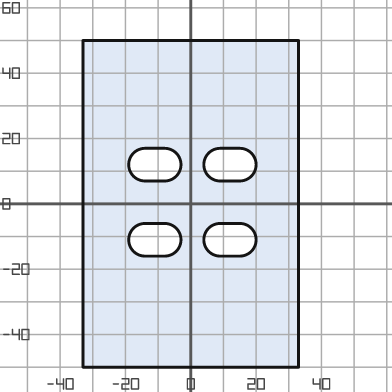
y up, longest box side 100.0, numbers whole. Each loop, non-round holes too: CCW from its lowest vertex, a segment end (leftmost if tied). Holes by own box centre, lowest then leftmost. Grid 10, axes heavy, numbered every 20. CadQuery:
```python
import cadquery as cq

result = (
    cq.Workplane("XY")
    .moveTo(-33.0, -50.0)
    .lineTo(33.0, -50.0)
    .lineTo(33.0, 50.0)
    .lineTo(-33.0, 50.0)
    .close()
    .moveTo(-14.0, -16.0)
    .lineTo(-8.0, -16.0)
    .threePointArc((-3.0, -11.0), (-8.0, -6.0))
    .lineTo(-14.0, -6.0)
    .threePointArc((-19.0, -11.0), (-14.0, -16.0))
    .close()
    .moveTo(9.0, -16.0)
    .lineTo(15.0, -16.0)
    .threePointArc((20.0, -11.0), (15.0, -6.0))
    .lineTo(9.0, -6.0)
    .threePointArc((4.0, -11.0), (9.0, -16.0))
    .close()
    .moveTo(-14.0, 7.0)
    .lineTo(-8.0, 7.0)
    .threePointArc((-3.0, 12.0), (-8.0, 17.0))
    .lineTo(-14.0, 17.0)
    .threePointArc((-19.0, 12.0), (-14.0, 7.0))
    .close()
    .moveTo(9.0, 7.0)
    .lineTo(15.0, 7.0)
    .threePointArc((20.0, 12.0), (15.0, 17.0))
    .lineTo(9.0, 17.0)
    .threePointArc((4.0, 12.0), (9.0, 7.0))
    .close()
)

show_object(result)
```